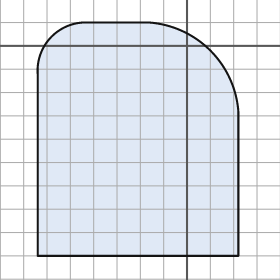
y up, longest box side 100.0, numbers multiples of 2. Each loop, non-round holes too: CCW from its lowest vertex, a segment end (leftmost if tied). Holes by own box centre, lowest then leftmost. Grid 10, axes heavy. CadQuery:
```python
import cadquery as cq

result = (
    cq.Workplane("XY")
    .moveTo(-64.0, -90.0)
    .lineTo(22.0, -90.0)
    .lineTo(22.0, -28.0)
    .threePointArc((10.0, -2.0), (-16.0, 10.0))
    .lineTo(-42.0, 10.0)
    .threePointArc((-58.0, 4.0), (-64.0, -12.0))
    .close()
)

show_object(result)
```